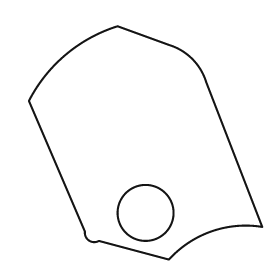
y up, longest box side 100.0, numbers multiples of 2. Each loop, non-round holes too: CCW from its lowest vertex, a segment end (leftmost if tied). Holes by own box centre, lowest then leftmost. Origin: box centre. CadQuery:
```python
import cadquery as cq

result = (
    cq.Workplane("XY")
    .moveTo(10.0, -50.0)
    .threePointArc((28.0, -38.0), (50.0, -36.0))
    .lineTo(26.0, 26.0)
    .threePointArc((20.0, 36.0), (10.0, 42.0))
    .lineTo(-12.0, 50.0)
    .threePointArc((-34.0, 38.0), (-50.0, 18.0))
    .lineTo(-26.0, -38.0)
    .threePointArc((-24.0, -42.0), (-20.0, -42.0))
    .close()
    .moveTo(0.0, -30.0)
    .circle(12.0)
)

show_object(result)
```